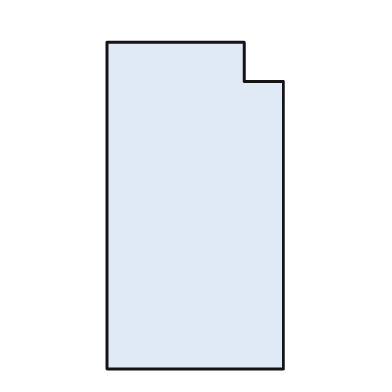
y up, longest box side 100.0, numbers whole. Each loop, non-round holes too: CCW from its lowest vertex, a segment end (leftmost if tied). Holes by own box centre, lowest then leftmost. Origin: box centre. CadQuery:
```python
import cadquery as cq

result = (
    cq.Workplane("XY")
    .moveTo(-27.0, -50.0)
    .lineTo(27.0, -50.0)
    .lineTo(27.0, 38.0)
    .lineTo(15.0, 38.0)
    .lineTo(15.0, 50.0)
    .lineTo(-27.0, 50.0)
    .close()
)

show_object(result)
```